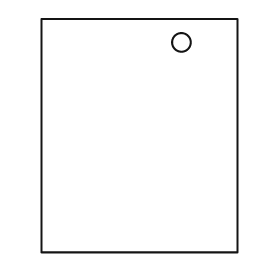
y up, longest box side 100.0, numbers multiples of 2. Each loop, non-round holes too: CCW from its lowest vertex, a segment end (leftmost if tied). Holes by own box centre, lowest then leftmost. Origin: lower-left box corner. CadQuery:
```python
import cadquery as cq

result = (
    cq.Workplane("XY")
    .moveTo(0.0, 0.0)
    .lineTo(84.0, 0.0)
    .lineTo(84.0, 100.0)
    .lineTo(0.0, 100.0)
    .close()
    .moveTo(60.0, 90.0)
    .circle(4.0)
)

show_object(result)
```